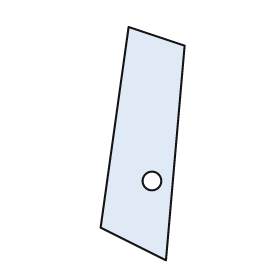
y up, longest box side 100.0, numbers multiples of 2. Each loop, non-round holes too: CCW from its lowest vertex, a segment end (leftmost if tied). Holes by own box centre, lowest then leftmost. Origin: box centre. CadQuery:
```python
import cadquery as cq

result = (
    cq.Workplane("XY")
    .moveTo(10.0, -50.0)
    .lineTo(18.0, 42.0)
    .lineTo(-6.0, 50.0)
    .lineTo(-18.0, -36.0)
    .close()
    .moveTo(4.0, -16.0)
    .circle(4.0)
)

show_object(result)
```